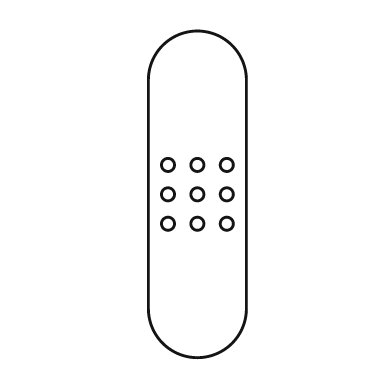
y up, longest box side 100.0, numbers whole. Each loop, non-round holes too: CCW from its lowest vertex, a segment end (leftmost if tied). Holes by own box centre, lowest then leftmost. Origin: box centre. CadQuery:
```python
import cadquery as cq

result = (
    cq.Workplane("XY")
    .moveTo(-15.0, -35.0)
    .threePointArc((0.0, -50.0), (15.0, -35.0))
    .lineTo(15.0, 35.0)
    .threePointArc((0.0, 50.0), (-15.0, 35.0))
    .close()
    .moveTo(-9.0, -9.0)
    .circle(2.0)
    .moveTo(0.0, -9.0)
    .circle(2.0)
    .moveTo(9.0, -9.0)
    .circle(2.0)
    .moveTo(-9.0, 0.0)
    .circle(2.0)
    .moveTo(0.0, 0.0)
    .circle(2.0)
    .moveTo(9.0, 0.0)
    .circle(2.0)
    .moveTo(-9.0, 9.0)
    .circle(2.0)
    .moveTo(0.0, 9.0)
    .circle(2.0)
    .moveTo(9.0, 9.0)
    .circle(2.0)
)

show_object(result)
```